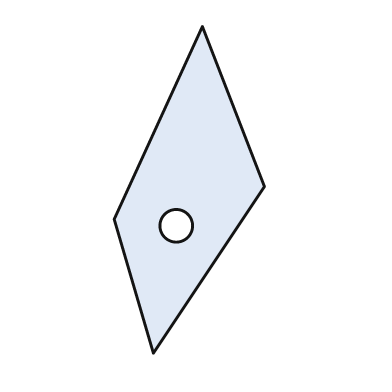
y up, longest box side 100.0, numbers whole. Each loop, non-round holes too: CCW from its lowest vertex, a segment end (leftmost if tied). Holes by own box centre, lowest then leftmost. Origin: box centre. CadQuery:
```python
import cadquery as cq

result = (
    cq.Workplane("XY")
    .moveTo(-11.0, -50.0)
    .lineTo(23.0, 1.0)
    .lineTo(4.0, 50.0)
    .lineTo(-23.0, -9.0)
    .close()
    .moveTo(-4.0, -11.0)
    .circle(5.0)
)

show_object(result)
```